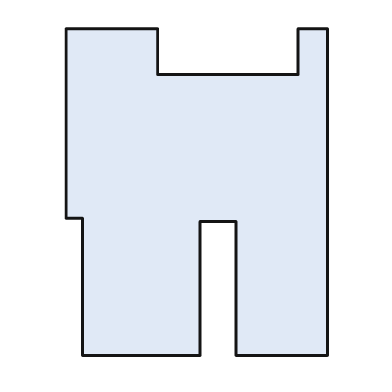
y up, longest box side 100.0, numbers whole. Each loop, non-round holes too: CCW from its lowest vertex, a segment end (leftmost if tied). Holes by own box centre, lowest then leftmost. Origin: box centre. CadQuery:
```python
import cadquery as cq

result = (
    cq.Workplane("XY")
    .moveTo(-35.0, -50.0)
    .lineTo(1.0, -50.0)
    .lineTo(1.0, -9.0)
    .lineTo(12.0, -9.0)
    .lineTo(12.0, -50.0)
    .lineTo(40.0, -50.0)
    .lineTo(40.0, 50.0)
    .lineTo(31.0, 50.0)
    .lineTo(31.0, 36.0)
    .lineTo(-12.0, 36.0)
    .lineTo(-12.0, 50.0)
    .lineTo(-40.0, 50.0)
    .lineTo(-40.0, -8.0)
    .lineTo(-35.0, -8.0)
    .close()
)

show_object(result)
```